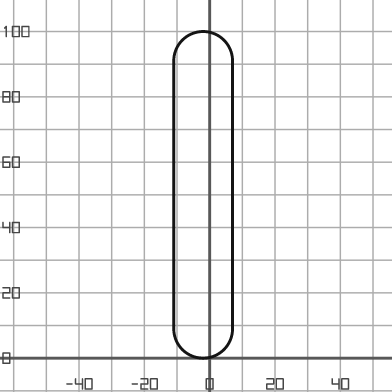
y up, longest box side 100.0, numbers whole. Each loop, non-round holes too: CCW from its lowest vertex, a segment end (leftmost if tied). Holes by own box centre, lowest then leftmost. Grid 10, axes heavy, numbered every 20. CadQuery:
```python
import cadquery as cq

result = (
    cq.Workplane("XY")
    .moveTo(-11.0, 9.0)
    .threePointArc((-2.0, 0.0), (7.0, 9.0))
    .lineTo(7.0, 91.0)
    .threePointArc((-2.0, 100.0), (-11.0, 91.0))
    .close()
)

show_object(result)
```